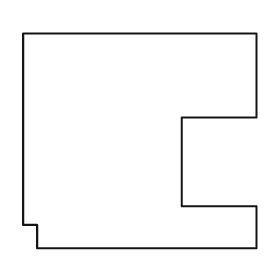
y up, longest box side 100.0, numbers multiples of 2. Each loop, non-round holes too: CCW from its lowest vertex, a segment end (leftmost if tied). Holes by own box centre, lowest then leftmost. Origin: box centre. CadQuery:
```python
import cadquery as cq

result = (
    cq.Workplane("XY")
    .moveTo(-44.0, -46.0)
    .lineTo(50.0, -46.0)
    .lineTo(50.0, -28.0)
    .lineTo(18.0, -28.0)
    .lineTo(18.0, 10.0)
    .lineTo(50.0, 10.0)
    .lineTo(50.0, 46.0)
    .lineTo(-50.0, 46.0)
    .lineTo(-50.0, -36.0)
    .lineTo(-44.0, -36.0)
    .close()
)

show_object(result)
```